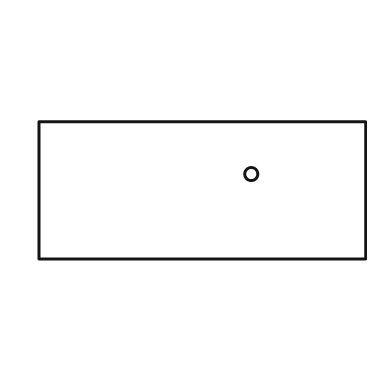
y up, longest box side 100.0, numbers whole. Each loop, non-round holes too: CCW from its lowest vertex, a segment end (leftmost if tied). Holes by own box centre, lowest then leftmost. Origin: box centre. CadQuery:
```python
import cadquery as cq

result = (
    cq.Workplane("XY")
    .moveTo(-50.0, -21.0)
    .lineTo(50.0, -21.0)
    .lineTo(50.0, 21.0)
    .lineTo(-50.0, 21.0)
    .close()
    .moveTo(15.0, 5.0)
    .circle(2.0)
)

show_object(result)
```